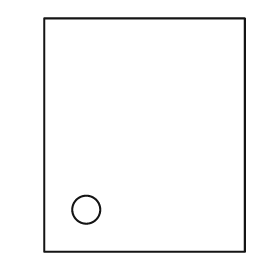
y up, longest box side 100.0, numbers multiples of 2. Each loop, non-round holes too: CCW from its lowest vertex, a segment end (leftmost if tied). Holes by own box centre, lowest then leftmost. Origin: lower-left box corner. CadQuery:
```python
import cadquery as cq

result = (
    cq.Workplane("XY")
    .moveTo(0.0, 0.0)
    .lineTo(86.0, 0.0)
    .lineTo(86.0, 100.0)
    .lineTo(0.0, 100.0)
    .close()
    .moveTo(18.0, 18.0)
    .circle(6.0)
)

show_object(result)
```